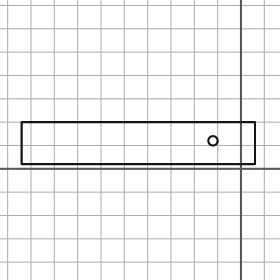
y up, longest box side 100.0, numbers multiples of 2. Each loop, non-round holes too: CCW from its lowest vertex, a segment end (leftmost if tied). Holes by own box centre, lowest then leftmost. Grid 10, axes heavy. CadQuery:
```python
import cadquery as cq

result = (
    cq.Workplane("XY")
    .moveTo(-94.0, 2.0)
    .lineTo(6.0, 2.0)
    .lineTo(6.0, 20.0)
    .lineTo(-94.0, 20.0)
    .close()
    .moveTo(-12.0, 12.0)
    .circle(2.0)
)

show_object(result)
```